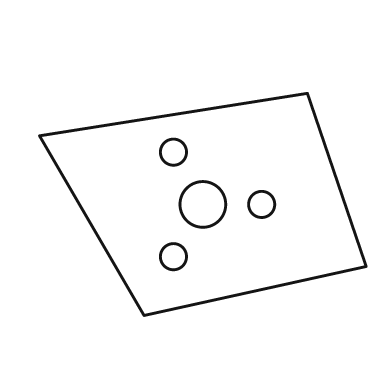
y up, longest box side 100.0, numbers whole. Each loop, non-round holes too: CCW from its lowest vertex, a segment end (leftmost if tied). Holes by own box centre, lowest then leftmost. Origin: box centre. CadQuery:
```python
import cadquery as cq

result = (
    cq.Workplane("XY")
    .moveTo(-18.0, -34.0)
    .lineTo(50.0, -19.0)
    .lineTo(32.0, 34.0)
    .lineTo(-50.0, 21.0)
    .close()
    .moveTo(-9.0, -16.0)
    .circle(4.0)
    .moveTo(0.0, 0.0)
    .circle(7.0)
    .moveTo(18.0, 0.0)
    .circle(4.0)
    .moveTo(-9.0, 16.0)
    .circle(4.0)
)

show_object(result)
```